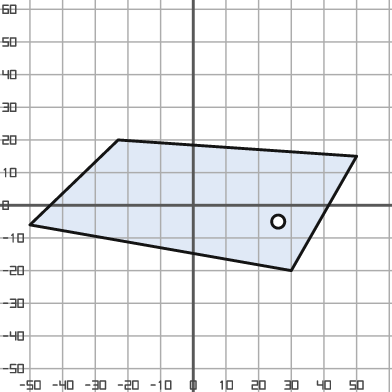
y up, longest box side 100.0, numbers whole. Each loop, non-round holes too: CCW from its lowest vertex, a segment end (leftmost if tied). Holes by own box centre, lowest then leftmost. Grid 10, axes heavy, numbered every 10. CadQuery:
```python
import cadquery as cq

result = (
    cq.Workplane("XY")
    .moveTo(30.0, -20.0)
    .lineTo(50.0, 15.0)
    .lineTo(-23.0, 20.0)
    .lineTo(-50.0, -6.0)
    .close()
    .moveTo(26.0, -5.0)
    .circle(2.0)
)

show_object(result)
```